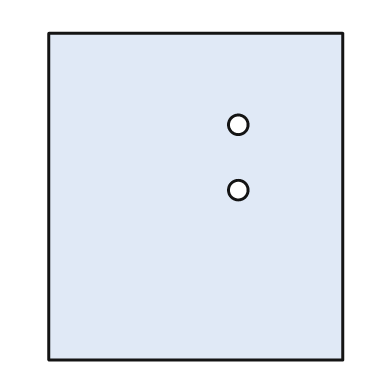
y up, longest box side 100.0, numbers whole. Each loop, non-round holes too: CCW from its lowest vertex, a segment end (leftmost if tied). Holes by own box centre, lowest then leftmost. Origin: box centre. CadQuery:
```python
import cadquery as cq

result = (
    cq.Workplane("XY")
    .moveTo(-45.0, -50.0)
    .lineTo(45.0, -50.0)
    .lineTo(45.0, 50.0)
    .lineTo(-45.0, 50.0)
    .close()
    .moveTo(13.0, 2.0)
    .circle(3.0)
    .moveTo(13.0, 22.0)
    .circle(3.0)
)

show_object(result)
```